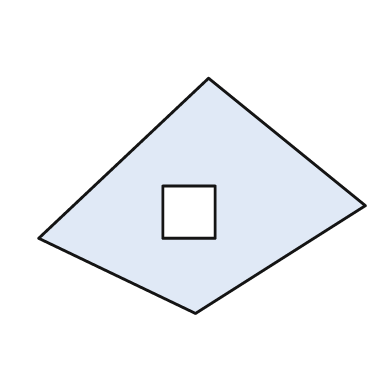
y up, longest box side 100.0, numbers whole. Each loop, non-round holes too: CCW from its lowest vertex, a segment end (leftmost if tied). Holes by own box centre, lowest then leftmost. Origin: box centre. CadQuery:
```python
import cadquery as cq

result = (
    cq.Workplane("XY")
    .moveTo(-2.0, -36.0)
    .lineTo(50.0, -3.0)
    .lineTo(2.0, 36.0)
    .lineTo(-50.0, -13.0)
    .close()
    .moveTo(-12.0, -13.0)
    .lineTo(4.0, -13.0)
    .lineTo(4.0, 3.0)
    .lineTo(-12.0, 3.0)
    .close()
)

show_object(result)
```